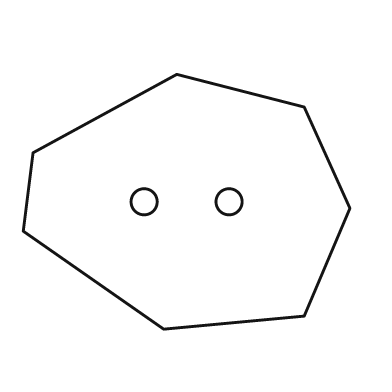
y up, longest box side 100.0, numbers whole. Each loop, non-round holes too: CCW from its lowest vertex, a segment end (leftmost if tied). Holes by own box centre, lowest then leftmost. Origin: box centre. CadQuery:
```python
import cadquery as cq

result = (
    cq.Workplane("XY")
    .moveTo(-7.0, -39.0)
    .lineTo(36.0, -35.0)
    .lineTo(50.0, -2.0)
    .lineTo(36.0, 29.0)
    .lineTo(-3.0, 39.0)
    .lineTo(-47.0, 15.0)
    .lineTo(-50.0, -9.0)
    .close()
    .moveTo(-13.0, 0.0)
    .circle(4.0)
    .moveTo(13.0, 0.0)
    .circle(4.0)
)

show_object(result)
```